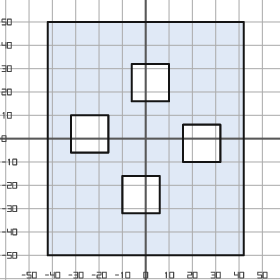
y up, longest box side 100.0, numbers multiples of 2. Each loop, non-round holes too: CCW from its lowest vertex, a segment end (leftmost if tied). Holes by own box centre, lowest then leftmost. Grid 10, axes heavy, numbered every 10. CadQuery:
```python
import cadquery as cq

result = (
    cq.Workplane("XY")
    .moveTo(-42.0, -50.0)
    .lineTo(42.0, -50.0)
    .lineTo(42.0, 50.0)
    .lineTo(-42.0, 50.0)
    .close()
    .moveTo(-10.0, -32.0)
    .lineTo(6.0, -32.0)
    .lineTo(6.0, -16.0)
    .lineTo(-10.0, -16.0)
    .close()
    .moveTo(16.0, -10.0)
    .lineTo(32.0, -10.0)
    .lineTo(32.0, 6.0)
    .lineTo(16.0, 6.0)
    .close()
    .moveTo(-32.0, -6.0)
    .lineTo(-16.0, -6.0)
    .lineTo(-16.0, 10.0)
    .lineTo(-32.0, 10.0)
    .close()
    .moveTo(-6.0, 16.0)
    .lineTo(10.0, 16.0)
    .lineTo(10.0, 32.0)
    .lineTo(-6.0, 32.0)
    .close()
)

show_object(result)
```